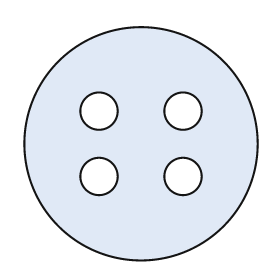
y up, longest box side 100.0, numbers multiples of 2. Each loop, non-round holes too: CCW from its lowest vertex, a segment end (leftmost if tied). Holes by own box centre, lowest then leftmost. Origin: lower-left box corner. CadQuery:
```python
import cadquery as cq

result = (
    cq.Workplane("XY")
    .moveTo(50.0, 50.0)
    .circle(50.0)
    .moveTo(32.0, 36.0)
    .circle(8.0)
    .moveTo(68.0, 36.0)
    .circle(8.0)
    .moveTo(32.0, 64.0)
    .circle(8.0)
    .moveTo(68.0, 64.0)
    .circle(8.0)
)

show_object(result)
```